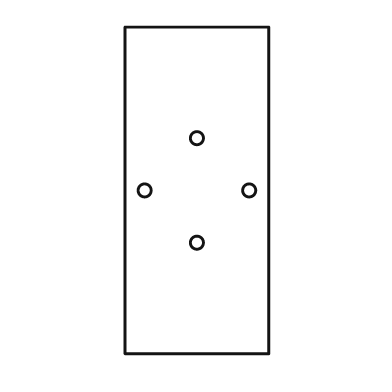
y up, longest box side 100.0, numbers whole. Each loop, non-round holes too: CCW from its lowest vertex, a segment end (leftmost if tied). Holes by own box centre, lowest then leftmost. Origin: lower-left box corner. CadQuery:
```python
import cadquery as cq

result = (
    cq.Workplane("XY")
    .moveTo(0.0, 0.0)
    .lineTo(44.0, 0.0)
    .lineTo(44.0, 100.0)
    .lineTo(0.0, 100.0)
    .close()
    .moveTo(22.0, 34.0)
    .circle(2.0)
    .moveTo(6.0, 50.0)
    .circle(2.0)
    .moveTo(38.0, 50.0)
    .circle(2.0)
    .moveTo(22.0, 66.0)
    .circle(2.0)
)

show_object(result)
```